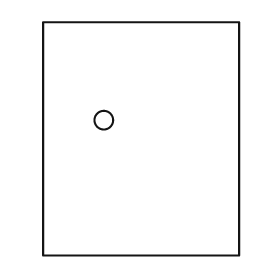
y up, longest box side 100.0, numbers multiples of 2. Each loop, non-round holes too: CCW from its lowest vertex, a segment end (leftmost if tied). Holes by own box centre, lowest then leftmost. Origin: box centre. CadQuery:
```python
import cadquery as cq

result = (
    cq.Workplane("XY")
    .moveTo(-42.0, -50.0)
    .lineTo(42.0, -50.0)
    .lineTo(42.0, 50.0)
    .lineTo(-42.0, 50.0)
    .close()
    .moveTo(-16.0, 8.0)
    .circle(4.0)
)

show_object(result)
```